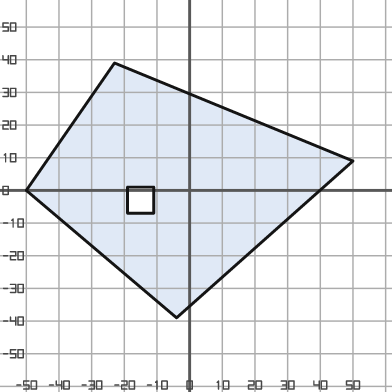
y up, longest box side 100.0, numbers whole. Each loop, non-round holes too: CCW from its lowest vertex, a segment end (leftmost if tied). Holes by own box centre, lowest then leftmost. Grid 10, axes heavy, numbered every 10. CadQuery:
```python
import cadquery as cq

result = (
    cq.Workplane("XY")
    .moveTo(-4.0, -39.0)
    .lineTo(50.0, 9.0)
    .lineTo(-23.0, 39.0)
    .lineTo(-50.0, 0.0)
    .close()
    .moveTo(-19.0, -7.0)
    .lineTo(-11.0, -7.0)
    .lineTo(-11.0, 1.0)
    .lineTo(-19.0, 1.0)
    .close()
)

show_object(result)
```